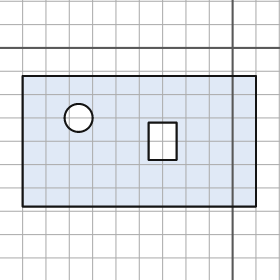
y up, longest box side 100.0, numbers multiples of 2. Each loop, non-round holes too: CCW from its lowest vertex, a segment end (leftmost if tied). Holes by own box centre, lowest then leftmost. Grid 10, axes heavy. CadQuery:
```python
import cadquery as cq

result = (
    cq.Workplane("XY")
    .moveTo(-90.0, -68.0)
    .lineTo(10.0, -68.0)
    .lineTo(10.0, -12.0)
    .lineTo(-90.0, -12.0)
    .close()
    .moveTo(-36.0, -48.0)
    .lineTo(-24.0, -48.0)
    .lineTo(-24.0, -32.0)
    .lineTo(-36.0, -32.0)
    .close()
    .moveTo(-66.0, -30.0)
    .circle(6.0)
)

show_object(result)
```